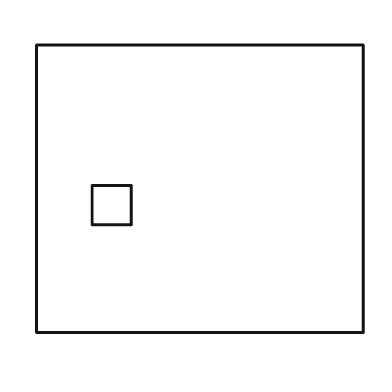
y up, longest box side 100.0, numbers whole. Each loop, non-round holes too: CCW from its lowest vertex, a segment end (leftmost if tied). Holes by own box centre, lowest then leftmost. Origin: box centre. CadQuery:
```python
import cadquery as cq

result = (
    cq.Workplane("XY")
    .moveTo(-50.0, -44.0)
    .lineTo(50.0, -44.0)
    .lineTo(50.0, 44.0)
    .lineTo(-50.0, 44.0)
    .close()
    .moveTo(-33.0, -11.0)
    .lineTo(-21.0, -11.0)
    .lineTo(-21.0, 1.0)
    .lineTo(-33.0, 1.0)
    .close()
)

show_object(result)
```